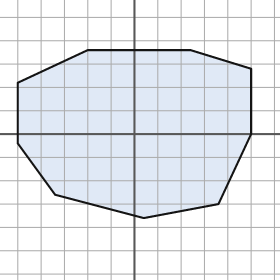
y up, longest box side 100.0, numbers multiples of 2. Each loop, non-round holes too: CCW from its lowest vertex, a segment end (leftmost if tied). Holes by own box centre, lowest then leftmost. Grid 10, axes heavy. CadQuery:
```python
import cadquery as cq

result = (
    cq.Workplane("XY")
    .moveTo(4.0, -36.0)
    .lineTo(36.0, -30.0)
    .lineTo(50.0, 0.0)
    .lineTo(50.0, 28.0)
    .lineTo(24.0, 36.0)
    .lineTo(-20.0, 36.0)
    .lineTo(-50.0, 22.0)
    .lineTo(-50.0, -4.0)
    .lineTo(-34.0, -26.0)
    .close()
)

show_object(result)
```